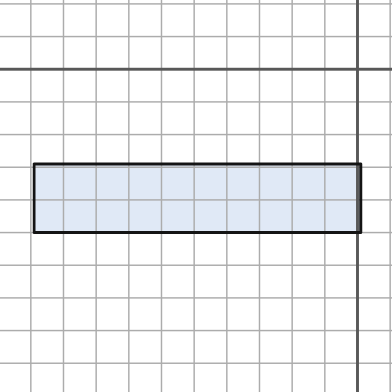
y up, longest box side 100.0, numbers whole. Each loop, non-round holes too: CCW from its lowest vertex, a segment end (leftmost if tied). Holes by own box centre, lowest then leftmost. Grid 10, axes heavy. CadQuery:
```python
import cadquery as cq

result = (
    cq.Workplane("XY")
    .moveTo(-99.0, -50.0)
    .lineTo(1.0, -50.0)
    .lineTo(1.0, -29.0)
    .lineTo(-99.0, -29.0)
    .close()
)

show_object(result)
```